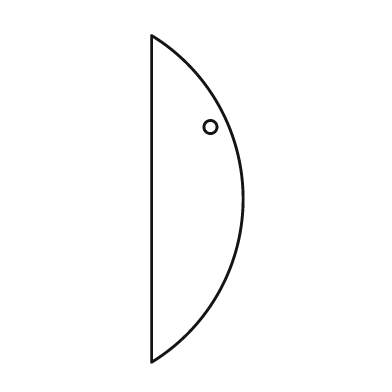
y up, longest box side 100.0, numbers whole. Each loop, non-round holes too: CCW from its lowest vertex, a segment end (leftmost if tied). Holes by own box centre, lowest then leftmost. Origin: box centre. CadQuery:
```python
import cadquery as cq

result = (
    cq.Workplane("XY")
    .moveTo(-14.0, -50.0)
    .threePointArc((14.0, 0.0), (-14.0, 50.0))
    .close()
    .moveTo(4.0, 22.0)
    .circle(2.0)
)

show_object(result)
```